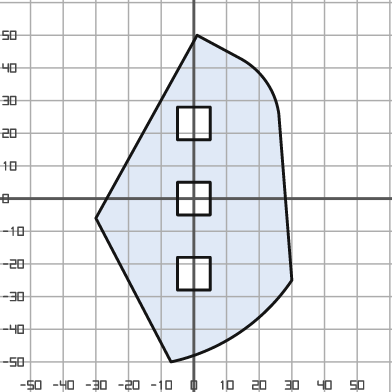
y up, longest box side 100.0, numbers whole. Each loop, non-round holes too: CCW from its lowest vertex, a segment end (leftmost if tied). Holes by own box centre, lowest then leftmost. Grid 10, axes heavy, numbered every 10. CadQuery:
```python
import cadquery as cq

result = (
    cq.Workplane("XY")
    .moveTo(-7.0, -50.0)
    .threePointArc((14.0, -41.0), (30.0, -25.0))
    .lineTo(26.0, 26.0)
    .threePointArc((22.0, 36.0), (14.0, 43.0))
    .lineTo(1.0, 50.0)
    .lineTo(-30.0, -6.0)
    .close()
    .moveTo(-5.0, -28.0)
    .lineTo(5.0, -28.0)
    .lineTo(5.0, -18.0)
    .lineTo(-5.0, -18.0)
    .close()
    .moveTo(-5.0, -5.0)
    .lineTo(5.0, -5.0)
    .lineTo(5.0, 5.0)
    .lineTo(-5.0, 5.0)
    .close()
    .moveTo(-5.0, 18.0)
    .lineTo(5.0, 18.0)
    .lineTo(5.0, 28.0)
    .lineTo(-5.0, 28.0)
    .close()
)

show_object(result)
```